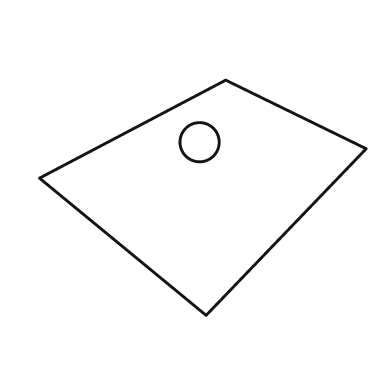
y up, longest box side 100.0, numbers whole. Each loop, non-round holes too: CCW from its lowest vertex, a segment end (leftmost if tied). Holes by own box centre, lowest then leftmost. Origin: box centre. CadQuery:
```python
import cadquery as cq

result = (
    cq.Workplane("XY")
    .moveTo(1.0, -36.0)
    .lineTo(50.0, 15.0)
    .lineTo(7.0, 36.0)
    .lineTo(-50.0, 6.0)
    .close()
    .moveTo(-1.0, 17.0)
    .circle(6.0)
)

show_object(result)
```